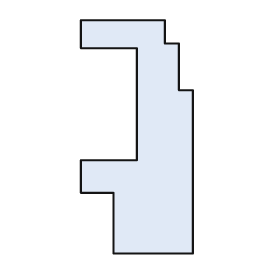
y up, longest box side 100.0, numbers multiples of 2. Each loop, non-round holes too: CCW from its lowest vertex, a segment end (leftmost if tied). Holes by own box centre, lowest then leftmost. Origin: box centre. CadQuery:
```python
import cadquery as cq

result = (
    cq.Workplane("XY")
    .moveTo(-10.0, -50.0)
    .lineTo(24.0, -50.0)
    .lineTo(24.0, 20.0)
    .lineTo(18.0, 20.0)
    .lineTo(18.0, 40.0)
    .lineTo(12.0, 40.0)
    .lineTo(12.0, 50.0)
    .lineTo(-24.0, 50.0)
    .lineTo(-24.0, 38.0)
    .lineTo(0.0, 38.0)
    .lineTo(0.0, -10.0)
    .lineTo(-24.0, -10.0)
    .lineTo(-24.0, -24.0)
    .lineTo(-10.0, -24.0)
    .close()
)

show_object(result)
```